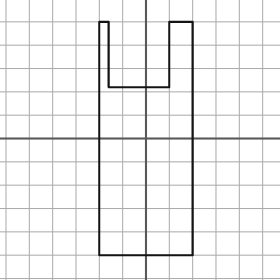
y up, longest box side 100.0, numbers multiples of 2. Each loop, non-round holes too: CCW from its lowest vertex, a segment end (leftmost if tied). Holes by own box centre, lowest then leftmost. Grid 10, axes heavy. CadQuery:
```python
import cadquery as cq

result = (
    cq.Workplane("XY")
    .moveTo(-20.0, -50.0)
    .lineTo(20.0, -50.0)
    .lineTo(20.0, 50.0)
    .lineTo(10.0, 50.0)
    .lineTo(10.0, 22.0)
    .lineTo(-16.0, 22.0)
    .lineTo(-16.0, 50.0)
    .lineTo(-20.0, 50.0)
    .close()
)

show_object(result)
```